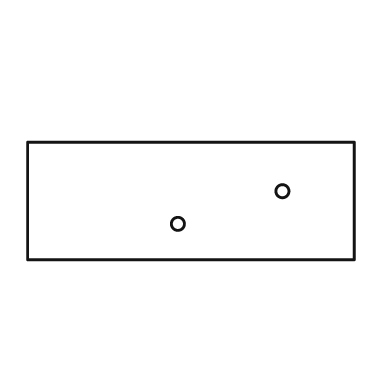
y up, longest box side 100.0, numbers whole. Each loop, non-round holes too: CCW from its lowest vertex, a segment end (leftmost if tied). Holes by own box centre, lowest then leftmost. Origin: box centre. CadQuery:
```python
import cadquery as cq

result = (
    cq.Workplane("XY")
    .moveTo(-50.0, -18.0)
    .lineTo(50.0, -18.0)
    .lineTo(50.0, 18.0)
    .lineTo(-50.0, 18.0)
    .close()
    .moveTo(-4.0, -7.0)
    .circle(2.0)
    .moveTo(28.0, 3.0)
    .circle(2.0)
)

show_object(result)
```